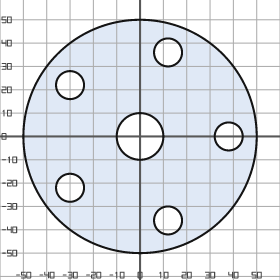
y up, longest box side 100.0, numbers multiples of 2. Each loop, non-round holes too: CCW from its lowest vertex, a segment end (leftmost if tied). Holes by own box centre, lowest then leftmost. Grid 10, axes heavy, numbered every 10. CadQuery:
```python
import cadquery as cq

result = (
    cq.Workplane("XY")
    .moveTo(0.0, 0.0)
    .circle(50.0)
    .moveTo(12.0, -36.0)
    .circle(6.0)
    .moveTo(-30.0, -22.0)
    .circle(6.0)
    .moveTo(0.0, 0.0)
    .circle(10.0)
    .moveTo(38.0, 0.0)
    .circle(6.0)
    .moveTo(-30.0, 22.0)
    .circle(6.0)
    .moveTo(12.0, 36.0)
    .circle(6.0)
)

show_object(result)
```